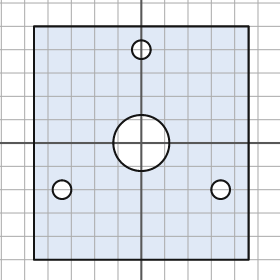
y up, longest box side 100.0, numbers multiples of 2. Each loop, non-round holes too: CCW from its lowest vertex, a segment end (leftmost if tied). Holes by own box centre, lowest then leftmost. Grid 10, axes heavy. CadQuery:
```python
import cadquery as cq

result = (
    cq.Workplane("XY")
    .moveTo(-46.0, -50.0)
    .lineTo(46.0, -50.0)
    .lineTo(46.0, 50.0)
    .lineTo(-46.0, 50.0)
    .close()
    .moveTo(-34.0, -20.0)
    .circle(4.0)
    .moveTo(34.0, -20.0)
    .circle(4.0)
    .moveTo(0.0, 0.0)
    .circle(12.0)
    .moveTo(0.0, 40.0)
    .circle(4.0)
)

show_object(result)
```